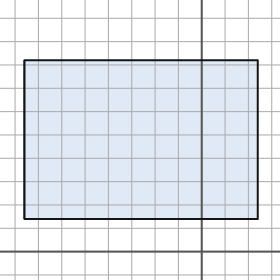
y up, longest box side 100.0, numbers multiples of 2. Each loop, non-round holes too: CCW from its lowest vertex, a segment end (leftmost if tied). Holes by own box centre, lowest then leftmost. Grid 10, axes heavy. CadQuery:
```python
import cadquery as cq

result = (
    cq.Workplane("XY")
    .moveTo(-76.0, 14.0)
    .lineTo(24.0, 14.0)
    .lineTo(24.0, 82.0)
    .lineTo(-76.0, 82.0)
    .close()
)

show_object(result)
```